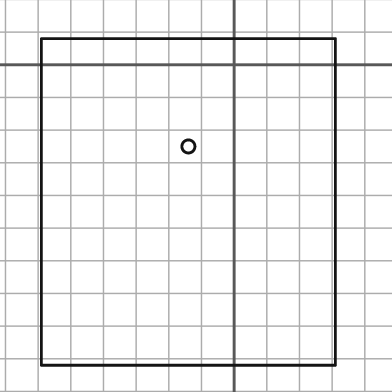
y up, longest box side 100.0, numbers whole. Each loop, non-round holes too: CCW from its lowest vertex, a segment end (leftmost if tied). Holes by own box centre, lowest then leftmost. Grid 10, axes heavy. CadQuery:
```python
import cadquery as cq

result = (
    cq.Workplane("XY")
    .moveTo(-59.0, -92.0)
    .lineTo(31.0, -92.0)
    .lineTo(31.0, 8.0)
    .lineTo(-59.0, 8.0)
    .close()
    .moveTo(-14.0, -25.0)
    .circle(2.0)
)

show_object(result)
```